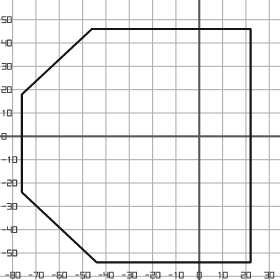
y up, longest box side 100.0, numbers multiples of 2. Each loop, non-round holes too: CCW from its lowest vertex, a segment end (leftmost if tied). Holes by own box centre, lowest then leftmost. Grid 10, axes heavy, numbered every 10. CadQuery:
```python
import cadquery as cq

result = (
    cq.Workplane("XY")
    .moveTo(-44.0, -54.0)
    .lineTo(22.0, -54.0)
    .lineTo(22.0, 46.0)
    .lineTo(-46.0, 46.0)
    .lineTo(-76.0, 18.0)
    .lineTo(-76.0, -24.0)
    .close()
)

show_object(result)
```